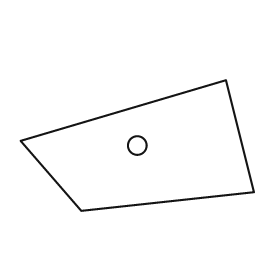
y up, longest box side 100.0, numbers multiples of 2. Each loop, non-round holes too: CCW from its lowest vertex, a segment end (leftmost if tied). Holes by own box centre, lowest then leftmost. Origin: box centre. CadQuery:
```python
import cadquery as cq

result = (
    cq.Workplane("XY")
    .moveTo(-24.0, -28.0)
    .lineTo(50.0, -20.0)
    .lineTo(38.0, 28.0)
    .lineTo(-50.0, 2.0)
    .close()
    .moveTo(0.0, 0.0)
    .circle(4.0)
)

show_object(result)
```